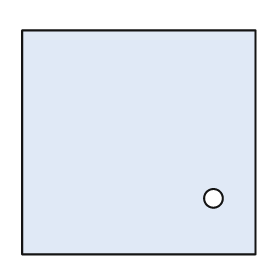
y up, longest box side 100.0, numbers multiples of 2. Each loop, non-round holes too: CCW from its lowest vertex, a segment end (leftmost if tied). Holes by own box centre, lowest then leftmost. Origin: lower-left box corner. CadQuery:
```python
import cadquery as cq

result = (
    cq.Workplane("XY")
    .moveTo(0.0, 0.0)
    .lineTo(100.0, 0.0)
    .lineTo(100.0, 96.0)
    .lineTo(0.0, 96.0)
    .close()
    .moveTo(82.0, 24.0)
    .circle(4.0)
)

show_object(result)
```